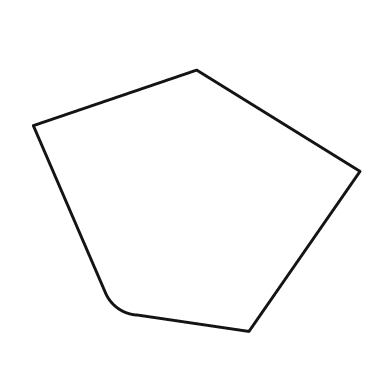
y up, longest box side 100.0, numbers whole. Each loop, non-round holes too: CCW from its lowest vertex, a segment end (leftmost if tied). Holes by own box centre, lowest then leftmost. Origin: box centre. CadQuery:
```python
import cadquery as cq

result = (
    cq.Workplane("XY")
    .moveTo(16.0, -40.0)
    .lineTo(50.0, 9.0)
    .lineTo(0.0, 40.0)
    .lineTo(-50.0, 23.0)
    .lineTo(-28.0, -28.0)
    .threePointArc((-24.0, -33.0), (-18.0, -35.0))
    .close()
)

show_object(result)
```